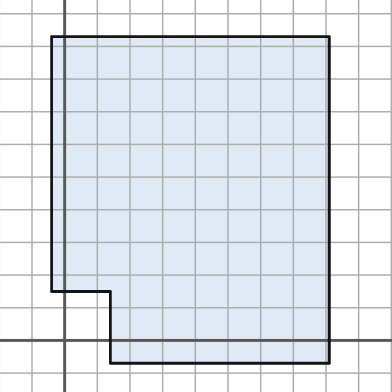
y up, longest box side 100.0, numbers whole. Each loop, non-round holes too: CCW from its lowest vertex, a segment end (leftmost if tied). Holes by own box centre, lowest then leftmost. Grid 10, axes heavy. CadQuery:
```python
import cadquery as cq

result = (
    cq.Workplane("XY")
    .moveTo(14.0, -7.0)
    .lineTo(81.0, -7.0)
    .lineTo(81.0, 93.0)
    .lineTo(-4.0, 93.0)
    .lineTo(-4.0, 15.0)
    .lineTo(14.0, 15.0)
    .close()
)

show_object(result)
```